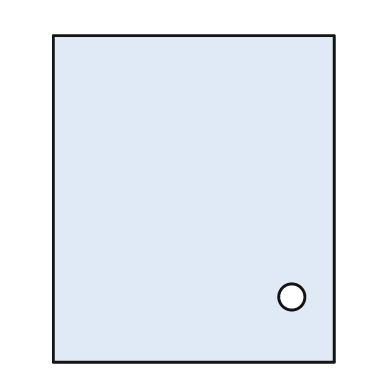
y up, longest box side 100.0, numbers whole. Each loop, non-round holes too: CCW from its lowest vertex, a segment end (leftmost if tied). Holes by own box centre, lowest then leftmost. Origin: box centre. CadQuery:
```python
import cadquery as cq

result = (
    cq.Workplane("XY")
    .moveTo(-43.0, -50.0)
    .lineTo(43.0, -50.0)
    .lineTo(43.0, 50.0)
    .lineTo(-43.0, 50.0)
    .close()
    .moveTo(30.0, -30.0)
    .circle(4.0)
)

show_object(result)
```